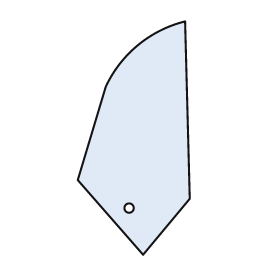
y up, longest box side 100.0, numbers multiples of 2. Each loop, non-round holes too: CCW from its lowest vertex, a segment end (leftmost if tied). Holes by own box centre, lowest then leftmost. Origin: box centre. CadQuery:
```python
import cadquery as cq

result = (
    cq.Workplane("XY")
    .moveTo(4.0, -50.0)
    .lineTo(24.0, -26.0)
    .lineTo(22.0, 50.0)
    .threePointArc((2.0, 40.0), (-12.0, 22.0))
    .lineTo(-24.0, -18.0)
    .close()
    .moveTo(-2.0, -30.0)
    .circle(2.0)
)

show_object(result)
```